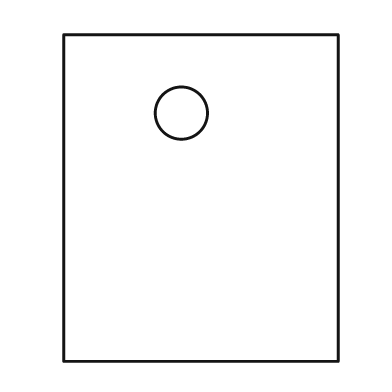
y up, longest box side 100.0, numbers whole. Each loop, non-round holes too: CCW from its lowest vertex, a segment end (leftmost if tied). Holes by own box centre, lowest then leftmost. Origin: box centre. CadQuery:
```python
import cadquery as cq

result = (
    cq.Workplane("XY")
    .moveTo(-42.0, -50.0)
    .lineTo(42.0, -50.0)
    .lineTo(42.0, 50.0)
    .lineTo(-42.0, 50.0)
    .close()
    .moveTo(-6.0, 26.0)
    .circle(8.0)
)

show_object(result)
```